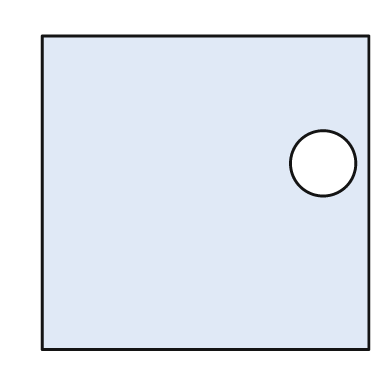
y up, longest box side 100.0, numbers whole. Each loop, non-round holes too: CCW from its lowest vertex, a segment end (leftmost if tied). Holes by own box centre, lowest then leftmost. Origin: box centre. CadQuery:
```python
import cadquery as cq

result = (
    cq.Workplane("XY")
    .moveTo(-50.0, -48.0)
    .lineTo(50.0, -48.0)
    .lineTo(50.0, 48.0)
    .lineTo(-50.0, 48.0)
    .close()
    .moveTo(36.0, 9.0)
    .circle(10.0)
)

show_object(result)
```